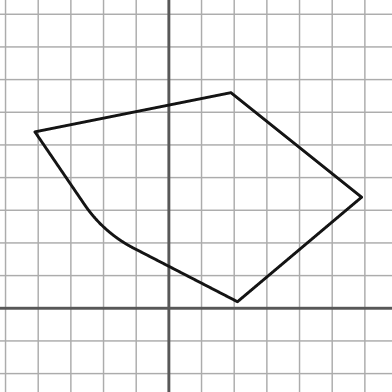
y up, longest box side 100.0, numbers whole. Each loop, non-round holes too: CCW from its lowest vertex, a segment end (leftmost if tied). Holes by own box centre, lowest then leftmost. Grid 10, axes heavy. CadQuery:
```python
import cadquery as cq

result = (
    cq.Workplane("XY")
    .moveTo(21.0, 2.0)
    .lineTo(59.0, 34.0)
    .lineTo(19.0, 66.0)
    .lineTo(-41.0, 54.0)
    .lineTo(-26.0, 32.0)
    .threePointArc((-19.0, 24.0), (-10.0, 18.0))
    .close()
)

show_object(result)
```